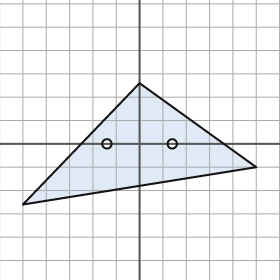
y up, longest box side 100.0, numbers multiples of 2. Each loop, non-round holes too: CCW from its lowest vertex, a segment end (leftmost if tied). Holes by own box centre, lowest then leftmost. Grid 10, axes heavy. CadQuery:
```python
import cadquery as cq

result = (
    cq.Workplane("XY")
    .moveTo(-50.0, -26.0)
    .lineTo(50.0, -10.0)
    .lineTo(0.0, 26.0)
    .close()
    .moveTo(-14.0, 0.0)
    .circle(2.0)
    .moveTo(14.0, 0.0)
    .circle(2.0)
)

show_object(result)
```